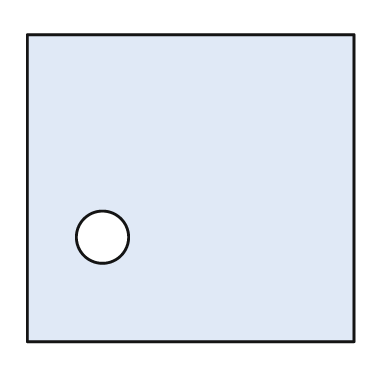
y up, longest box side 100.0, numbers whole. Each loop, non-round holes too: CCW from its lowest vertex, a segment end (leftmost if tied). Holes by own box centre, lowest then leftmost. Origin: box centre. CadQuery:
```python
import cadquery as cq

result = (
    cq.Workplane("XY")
    .moveTo(-50.0, -47.0)
    .lineTo(50.0, -47.0)
    .lineTo(50.0, 47.0)
    .lineTo(-50.0, 47.0)
    .close()
    .moveTo(-27.0, -15.0)
    .circle(8.0)
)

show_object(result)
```